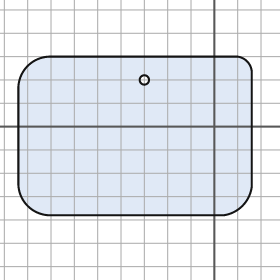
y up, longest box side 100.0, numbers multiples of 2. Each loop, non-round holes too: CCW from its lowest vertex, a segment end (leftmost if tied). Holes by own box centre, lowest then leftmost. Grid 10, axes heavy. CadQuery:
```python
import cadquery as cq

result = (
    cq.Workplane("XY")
    .moveTo(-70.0, -38.0)
    .lineTo(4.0, -38.0)
    .threePointArc((12.0, -34.0), (16.0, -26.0))
    .lineTo(16.0, 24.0)
    .threePointArc((14.0, 28.0), (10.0, 30.0))
    .lineTo(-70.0, 30.0)
    .threePointArc((-80.0, 26.0), (-84.0, 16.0))
    .lineTo(-84.0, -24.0)
    .threePointArc((-80.0, -34.0), (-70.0, -38.0))
    .close()
    .moveTo(-30.0, 20.0)
    .circle(2.0)
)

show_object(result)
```